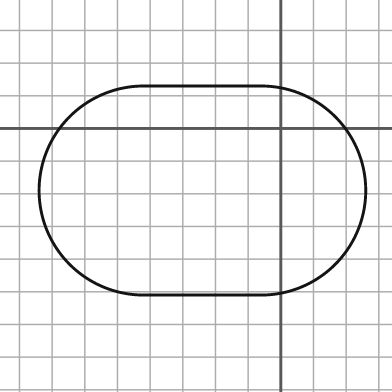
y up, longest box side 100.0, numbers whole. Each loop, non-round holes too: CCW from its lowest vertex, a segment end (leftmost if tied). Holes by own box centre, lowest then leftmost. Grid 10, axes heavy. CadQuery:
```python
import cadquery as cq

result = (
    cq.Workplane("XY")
    .moveTo(-42.0, -51.0)
    .lineTo(-6.0, -51.0)
    .threePointArc((26.0, -19.0), (-6.0, 13.0))
    .lineTo(-42.0, 13.0)
    .threePointArc((-74.0, -19.0), (-42.0, -51.0))
    .close()
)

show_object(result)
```